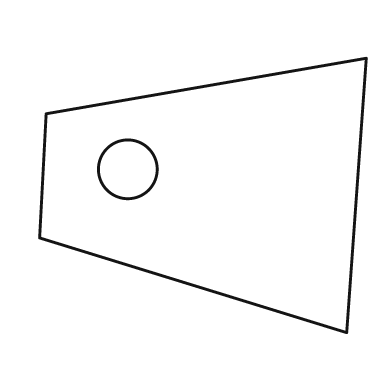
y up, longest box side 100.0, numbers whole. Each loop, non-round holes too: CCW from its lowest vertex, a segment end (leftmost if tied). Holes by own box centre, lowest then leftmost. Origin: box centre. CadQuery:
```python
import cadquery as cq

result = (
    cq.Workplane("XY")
    .moveTo(44.0, -42.0)
    .lineTo(50.0, 42.0)
    .lineTo(-48.0, 25.0)
    .lineTo(-50.0, -13.0)
    .close()
    .moveTo(-23.0, 8.0)
    .circle(9.0)
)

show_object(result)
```